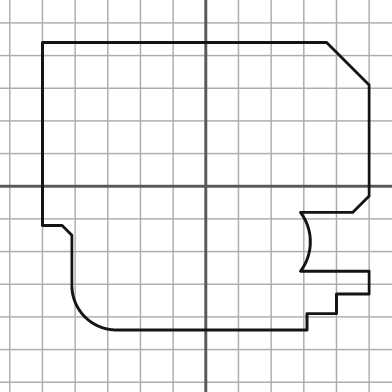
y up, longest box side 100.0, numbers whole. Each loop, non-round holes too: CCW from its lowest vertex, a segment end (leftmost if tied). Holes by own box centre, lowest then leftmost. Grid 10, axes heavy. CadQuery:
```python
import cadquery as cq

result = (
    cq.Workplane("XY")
    .moveTo(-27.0, -44.0)
    .lineTo(31.0, -44.0)
    .lineTo(31.0, -39.0)
    .lineTo(40.0, -39.0)
    .lineTo(40.0, -33.0)
    .lineTo(50.0, -33.0)
    .lineTo(50.0, -26.0)
    .lineTo(29.0, -26.0)
    .threePointArc((32.0, -17.0), (29.0, -8.0))
    .lineTo(45.0, -8.0)
    .lineTo(50.0, -3.0)
    .lineTo(50.0, 31.0)
    .lineTo(37.0, 44.0)
    .lineTo(-50.0, 44.0)
    .lineTo(-50.0, -12.0)
    .lineTo(-44.0, -12.0)
    .lineTo(-41.0, -15.0)
    .lineTo(-41.0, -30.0)
    .threePointArc((-37.0, -40.0), (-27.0, -44.0))
    .close()
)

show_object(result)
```